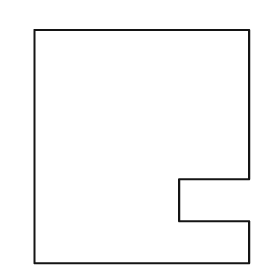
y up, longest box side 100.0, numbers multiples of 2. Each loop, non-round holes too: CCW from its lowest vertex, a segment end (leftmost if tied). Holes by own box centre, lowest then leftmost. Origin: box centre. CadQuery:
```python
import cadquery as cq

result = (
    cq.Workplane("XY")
    .moveTo(-46.0, -50.0)
    .lineTo(46.0, -50.0)
    .lineTo(46.0, -32.0)
    .lineTo(16.0, -32.0)
    .lineTo(16.0, -14.0)
    .lineTo(46.0, -14.0)
    .lineTo(46.0, 50.0)
    .lineTo(-46.0, 50.0)
    .close()
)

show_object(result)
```